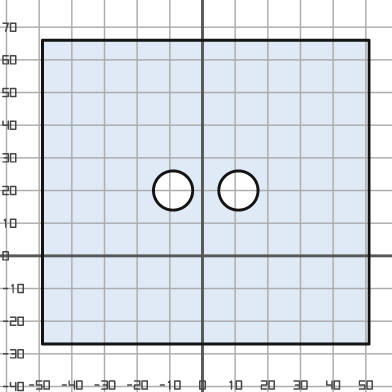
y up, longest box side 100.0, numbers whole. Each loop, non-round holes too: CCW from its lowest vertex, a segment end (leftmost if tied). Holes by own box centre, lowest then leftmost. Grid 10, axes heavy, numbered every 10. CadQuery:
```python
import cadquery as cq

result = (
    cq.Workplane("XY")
    .moveTo(-49.0, -27.0)
    .lineTo(51.0, -27.0)
    .lineTo(51.0, 66.0)
    .lineTo(-49.0, 66.0)
    .close()
    .moveTo(-9.0, 20.0)
    .circle(6.0)
    .moveTo(11.0, 20.0)
    .circle(6.0)
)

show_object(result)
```